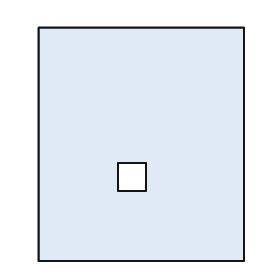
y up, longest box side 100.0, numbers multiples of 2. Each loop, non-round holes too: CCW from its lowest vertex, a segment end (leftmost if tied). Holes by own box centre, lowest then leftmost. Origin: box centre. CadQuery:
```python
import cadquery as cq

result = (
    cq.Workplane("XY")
    .moveTo(-44.0, -50.0)
    .lineTo(44.0, -50.0)
    .lineTo(44.0, 50.0)
    .lineTo(-44.0, 50.0)
    .close()
    .moveTo(-10.0, -20.0)
    .lineTo(2.0, -20.0)
    .lineTo(2.0, -8.0)
    .lineTo(-10.0, -8.0)
    .close()
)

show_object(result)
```